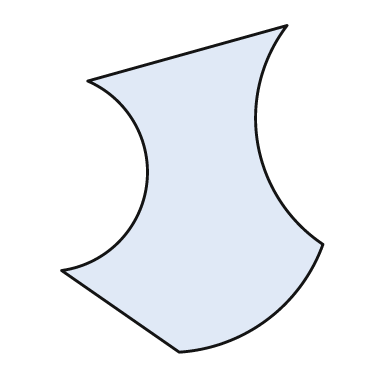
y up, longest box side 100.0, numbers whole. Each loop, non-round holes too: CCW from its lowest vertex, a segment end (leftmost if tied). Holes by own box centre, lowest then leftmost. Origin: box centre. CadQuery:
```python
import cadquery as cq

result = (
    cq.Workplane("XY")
    .moveTo(-4.0, -50.0)
    .threePointArc((23.0, -40.0), (40.0, -17.0))
    .threePointArc((20.0, 14.0), (29.0, 50.0))
    .lineTo(-32.0, 33.0)
    .threePointArc((-14.0, 1.0), (-40.0, -25.0))
    .close()
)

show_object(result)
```